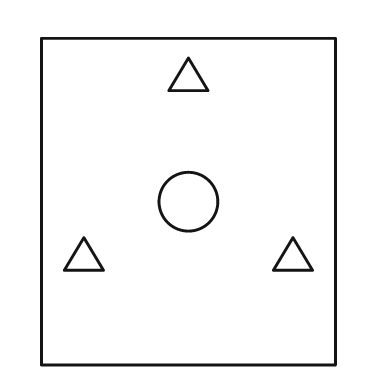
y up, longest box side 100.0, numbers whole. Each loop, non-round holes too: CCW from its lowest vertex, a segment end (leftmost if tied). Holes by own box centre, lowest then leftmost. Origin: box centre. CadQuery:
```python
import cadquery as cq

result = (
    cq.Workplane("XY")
    .moveTo(-45.0, -50.0)
    .lineTo(45.0, -50.0)
    .lineTo(45.0, 50.0)
    .lineTo(-45.0, 50.0)
    .close()
    .moveTo(-38.0, -21.0)
    .lineTo(-26.0, -21.0)
    .lineTo(-32.0, -11.0)
    .close()
    .moveTo(26.0, -21.0)
    .lineTo(38.0, -21.0)
    .lineTo(32.0, -11.0)
    .close()
    .moveTo(0.0, 0.0)
    .circle(9.0)
    .moveTo(-6.0, 34.0)
    .lineTo(6.0, 34.0)
    .lineTo(0.0, 44.0)
    .close()
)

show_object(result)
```